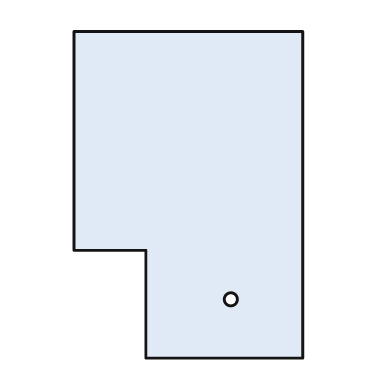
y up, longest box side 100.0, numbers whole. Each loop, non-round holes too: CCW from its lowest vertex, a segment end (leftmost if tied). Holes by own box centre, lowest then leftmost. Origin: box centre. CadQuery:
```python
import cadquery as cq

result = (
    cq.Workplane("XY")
    .moveTo(-13.0, -50.0)
    .lineTo(35.0, -50.0)
    .lineTo(35.0, 50.0)
    .lineTo(-35.0, 50.0)
    .lineTo(-35.0, -17.0)
    .lineTo(-13.0, -17.0)
    .close()
    .moveTo(13.0, -32.0)
    .circle(2.0)
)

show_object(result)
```